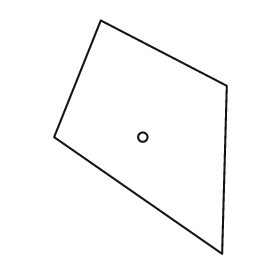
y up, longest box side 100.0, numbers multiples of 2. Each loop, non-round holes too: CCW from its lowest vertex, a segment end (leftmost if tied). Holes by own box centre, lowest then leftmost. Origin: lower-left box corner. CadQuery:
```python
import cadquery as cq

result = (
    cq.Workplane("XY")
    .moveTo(72.0, 0.0)
    .lineTo(74.0, 72.0)
    .lineTo(20.0, 100.0)
    .lineTo(0.0, 50.0)
    .close()
    .moveTo(38.0, 50.0)
    .circle(2.0)
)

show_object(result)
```